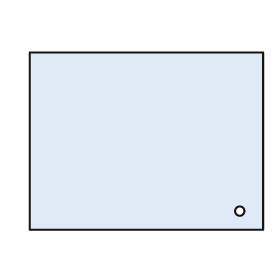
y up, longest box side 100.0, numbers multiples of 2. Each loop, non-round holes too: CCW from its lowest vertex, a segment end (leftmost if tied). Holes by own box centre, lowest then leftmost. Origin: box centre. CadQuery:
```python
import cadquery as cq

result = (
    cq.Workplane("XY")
    .moveTo(-50.0, -38.0)
    .lineTo(50.0, -38.0)
    .lineTo(50.0, 38.0)
    .lineTo(-50.0, 38.0)
    .close()
    .moveTo(40.0, -30.0)
    .circle(2.0)
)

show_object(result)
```